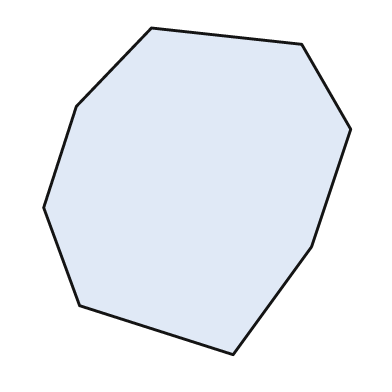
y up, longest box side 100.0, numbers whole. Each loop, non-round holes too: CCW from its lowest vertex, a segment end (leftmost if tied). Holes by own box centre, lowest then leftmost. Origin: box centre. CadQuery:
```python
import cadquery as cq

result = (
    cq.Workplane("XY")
    .moveTo(11.0, -50.0)
    .lineTo(35.0, -17.0)
    .lineTo(47.0, 19.0)
    .lineTo(32.0, 45.0)
    .lineTo(-14.0, 50.0)
    .lineTo(-37.0, 26.0)
    .lineTo(-47.0, -5.0)
    .lineTo(-36.0, -35.0)
    .close()
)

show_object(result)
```